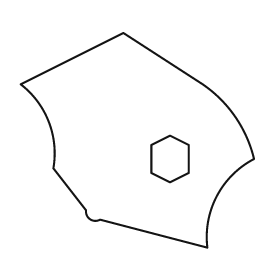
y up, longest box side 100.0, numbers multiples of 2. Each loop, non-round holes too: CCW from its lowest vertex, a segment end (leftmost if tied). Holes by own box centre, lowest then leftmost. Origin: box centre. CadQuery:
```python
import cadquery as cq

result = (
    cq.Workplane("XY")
    .moveTo(30.0, -46.0)
    .threePointArc((34.0, -24.0), (50.0, -8.0))
    .threePointArc((42.0, 10.0), (28.0, 24.0))
    .lineTo(-6.0, 46.0)
    .lineTo(-50.0, 24.0)
    .threePointArc((-38.0, 8.0), (-36.0, -12.0))
    .lineTo(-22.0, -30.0)
    .threePointArc((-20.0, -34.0), (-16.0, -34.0))
    .close()
    .moveTo(14.0, -18.0)
    .lineTo(22.0, -14.0)
    .lineTo(22.0, -2.0)
    .lineTo(14.0, 2.0)
    .lineTo(6.0, -2.0)
    .lineTo(6.0, -14.0)
    .close()
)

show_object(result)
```